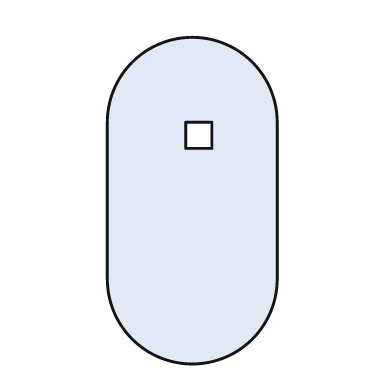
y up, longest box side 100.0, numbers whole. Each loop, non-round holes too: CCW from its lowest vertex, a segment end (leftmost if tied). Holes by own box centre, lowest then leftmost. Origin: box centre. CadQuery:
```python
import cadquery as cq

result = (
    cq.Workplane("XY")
    .moveTo(-26.0, -24.0)
    .threePointArc((0.0, -50.0), (26.0, -24.0))
    .lineTo(26.0, 24.0)
    .threePointArc((0.0, 50.0), (-26.0, 24.0))
    .close()
    .moveTo(-2.0, 16.0)
    .lineTo(6.0, 16.0)
    .lineTo(6.0, 24.0)
    .lineTo(-2.0, 24.0)
    .close()
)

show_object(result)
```